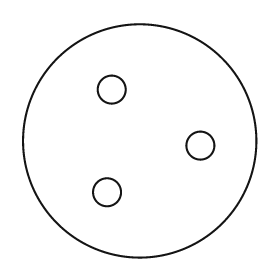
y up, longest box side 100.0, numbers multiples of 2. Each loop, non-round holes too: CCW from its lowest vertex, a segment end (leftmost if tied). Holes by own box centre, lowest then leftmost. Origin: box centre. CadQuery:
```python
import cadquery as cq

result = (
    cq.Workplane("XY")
    .moveTo(0.0, 0.0)
    .circle(50.0)
    .moveTo(-14.0, -22.0)
    .circle(6.0)
    .moveTo(26.0, -2.0)
    .circle(6.0)
    .moveTo(-12.0, 22.0)
    .circle(6.0)
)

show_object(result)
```